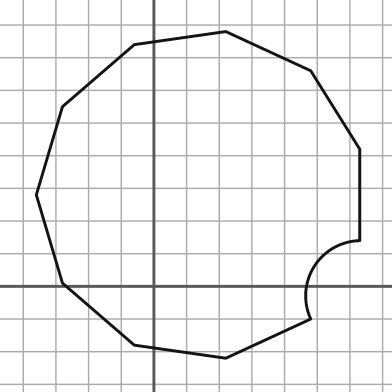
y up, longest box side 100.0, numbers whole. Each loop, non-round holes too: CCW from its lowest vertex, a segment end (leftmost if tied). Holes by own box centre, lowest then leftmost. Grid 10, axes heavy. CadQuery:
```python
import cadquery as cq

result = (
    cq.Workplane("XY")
    .moveTo(22.0, -22.0)
    .lineTo(48.0, -10.0)
    .threePointArc((49.0, 6.0), (63.0, 14.0))
    .lineTo(63.0, 42.0)
    .lineTo(48.0, 66.0)
    .lineTo(22.0, 78.0)
    .lineTo(-6.0, 74.0)
    .lineTo(-28.0, 55.0)
    .lineTo(-36.0, 28.0)
    .lineTo(-28.0, 1.0)
    .lineTo(-6.0, -18.0)
    .close()
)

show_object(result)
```